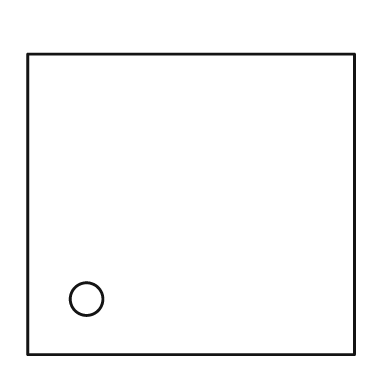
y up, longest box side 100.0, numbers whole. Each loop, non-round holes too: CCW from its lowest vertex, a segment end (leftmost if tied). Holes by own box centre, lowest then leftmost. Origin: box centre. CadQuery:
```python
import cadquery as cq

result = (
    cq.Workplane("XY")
    .moveTo(-50.0, -46.0)
    .lineTo(50.0, -46.0)
    .lineTo(50.0, 46.0)
    .lineTo(-50.0, 46.0)
    .close()
    .moveTo(-32.0, -29.0)
    .circle(5.0)
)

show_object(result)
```